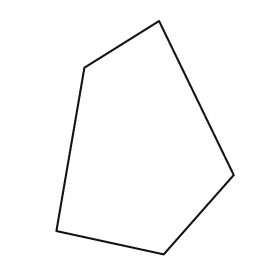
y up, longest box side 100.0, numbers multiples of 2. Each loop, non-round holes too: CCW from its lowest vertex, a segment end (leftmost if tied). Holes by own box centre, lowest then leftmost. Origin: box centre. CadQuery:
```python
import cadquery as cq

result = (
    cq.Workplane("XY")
    .moveTo(8.0, -50.0)
    .lineTo(38.0, -16.0)
    .lineTo(6.0, 50.0)
    .lineTo(-26.0, 30.0)
    .lineTo(-38.0, -40.0)
    .close()
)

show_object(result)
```